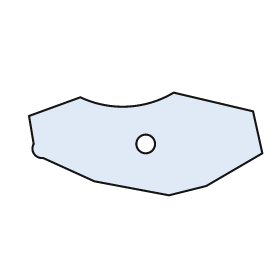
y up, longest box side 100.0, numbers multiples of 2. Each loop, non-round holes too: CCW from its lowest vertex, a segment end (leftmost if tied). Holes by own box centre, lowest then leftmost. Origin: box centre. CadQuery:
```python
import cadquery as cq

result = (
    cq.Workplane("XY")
    .moveTo(10.0, -22.0)
    .lineTo(26.0, -18.0)
    .lineTo(50.0, -4.0)
    .lineTo(46.0, 14.0)
    .lineTo(12.0, 22.0)
    .threePointArc((-8.0, 16.0), (-28.0, 20.0))
    .lineTo(-50.0, 12.0)
    .lineTo(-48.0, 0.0)
    .threePointArc((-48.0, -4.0), (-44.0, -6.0))
    .lineTo(-22.0, -16.0)
    .close()
    .moveTo(0.0, 0.0)
    .circle(4.0)
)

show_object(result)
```